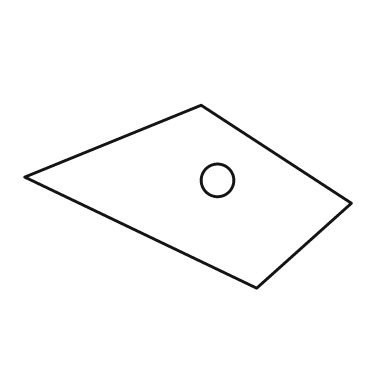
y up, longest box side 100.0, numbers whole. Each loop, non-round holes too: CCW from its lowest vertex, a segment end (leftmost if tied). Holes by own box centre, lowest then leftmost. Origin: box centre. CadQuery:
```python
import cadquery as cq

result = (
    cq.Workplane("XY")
    .moveTo(21.0, -28.0)
    .lineTo(50.0, -2.0)
    .lineTo(4.0, 28.0)
    .lineTo(-50.0, 6.0)
    .close()
    .moveTo(9.0, 5.0)
    .circle(5.0)
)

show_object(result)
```